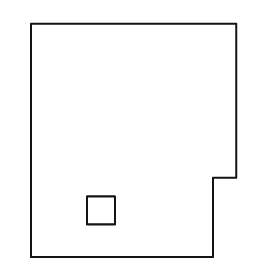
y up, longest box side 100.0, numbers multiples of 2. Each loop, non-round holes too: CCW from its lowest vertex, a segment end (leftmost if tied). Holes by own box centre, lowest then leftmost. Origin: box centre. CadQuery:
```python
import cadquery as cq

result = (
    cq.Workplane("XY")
    .moveTo(-44.0, -50.0)
    .lineTo(34.0, -50.0)
    .lineTo(34.0, -16.0)
    .lineTo(44.0, -16.0)
    .lineTo(44.0, 50.0)
    .lineTo(-44.0, 50.0)
    .close()
    .moveTo(-20.0, -36.0)
    .lineTo(-8.0, -36.0)
    .lineTo(-8.0, -24.0)
    .lineTo(-20.0, -24.0)
    .close()
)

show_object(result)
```